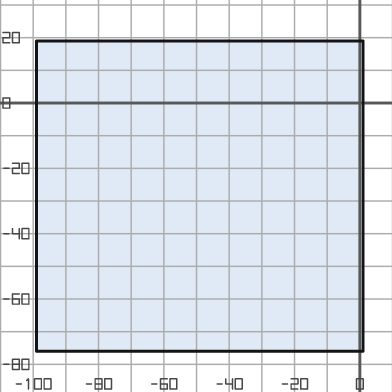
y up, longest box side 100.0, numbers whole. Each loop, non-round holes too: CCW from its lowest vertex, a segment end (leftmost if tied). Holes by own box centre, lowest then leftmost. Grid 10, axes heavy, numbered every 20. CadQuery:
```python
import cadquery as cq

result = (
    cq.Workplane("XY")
    .moveTo(-99.0, -76.0)
    .lineTo(1.0, -76.0)
    .lineTo(1.0, 19.0)
    .lineTo(-99.0, 19.0)
    .close()
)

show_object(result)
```